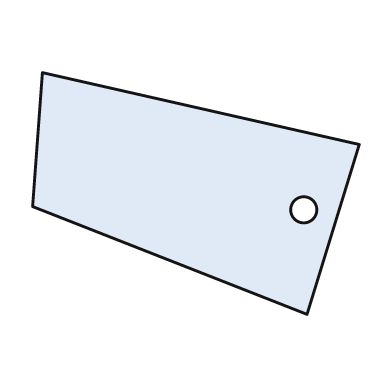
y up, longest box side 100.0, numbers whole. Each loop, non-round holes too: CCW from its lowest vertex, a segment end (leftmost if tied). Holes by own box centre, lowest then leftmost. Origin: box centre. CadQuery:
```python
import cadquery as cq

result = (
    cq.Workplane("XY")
    .moveTo(34.0, -37.0)
    .lineTo(50.0, 15.0)
    .lineTo(-47.0, 37.0)
    .lineTo(-50.0, -4.0)
    .close()
    .moveTo(33.0, -5.0)
    .circle(4.0)
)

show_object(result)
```